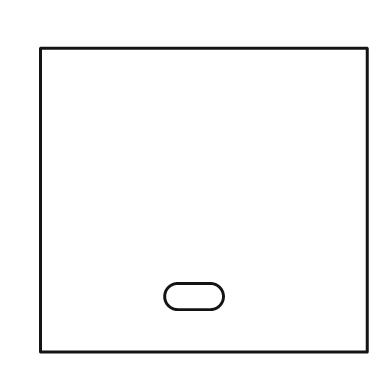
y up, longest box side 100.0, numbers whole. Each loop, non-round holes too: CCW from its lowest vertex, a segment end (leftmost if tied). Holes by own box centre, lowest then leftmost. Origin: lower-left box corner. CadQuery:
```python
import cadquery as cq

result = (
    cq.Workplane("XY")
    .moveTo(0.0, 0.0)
    .lineTo(100.0, 0.0)
    .lineTo(100.0, 93.0)
    .lineTo(0.0, 93.0)
    .close()
    .moveTo(42.0, 13.0)
    .lineTo(52.0, 13.0)
    .threePointArc((56.0, 17.0), (52.0, 21.0))
    .lineTo(42.0, 21.0)
    .threePointArc((38.0, 17.0), (42.0, 13.0))
    .close()
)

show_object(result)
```